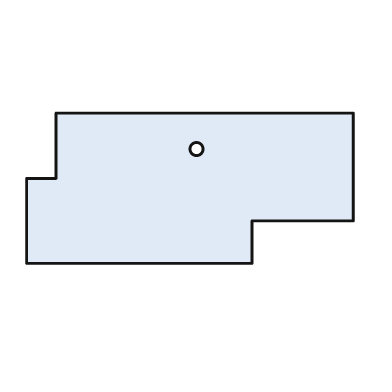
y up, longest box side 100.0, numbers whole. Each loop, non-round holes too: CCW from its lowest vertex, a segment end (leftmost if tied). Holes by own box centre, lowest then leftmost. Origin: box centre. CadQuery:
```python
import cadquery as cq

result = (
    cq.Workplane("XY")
    .moveTo(-50.0, -23.0)
    .lineTo(19.0, -23.0)
    .lineTo(19.0, -10.0)
    .lineTo(50.0, -10.0)
    .lineTo(50.0, 23.0)
    .lineTo(-41.0, 23.0)
    .lineTo(-41.0, 3.0)
    .lineTo(-50.0, 3.0)
    .close()
    .moveTo(2.0, 12.0)
    .circle(2.0)
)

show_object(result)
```